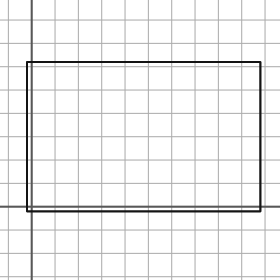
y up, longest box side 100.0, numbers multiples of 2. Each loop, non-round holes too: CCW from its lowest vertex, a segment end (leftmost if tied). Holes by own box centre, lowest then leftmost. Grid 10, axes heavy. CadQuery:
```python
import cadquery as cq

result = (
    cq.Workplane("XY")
    .moveTo(-2.0, -2.0)
    .lineTo(98.0, -2.0)
    .lineTo(98.0, 62.0)
    .lineTo(-2.0, 62.0)
    .close()
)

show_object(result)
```